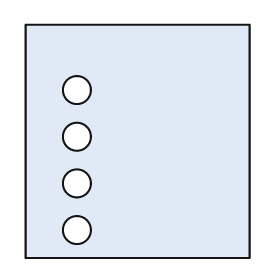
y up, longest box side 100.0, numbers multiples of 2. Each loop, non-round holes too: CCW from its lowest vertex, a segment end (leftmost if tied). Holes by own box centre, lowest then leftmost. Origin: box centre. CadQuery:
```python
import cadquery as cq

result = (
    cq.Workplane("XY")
    .moveTo(-48.0, -50.0)
    .lineTo(48.0, -50.0)
    .lineTo(48.0, 50.0)
    .lineTo(-48.0, 50.0)
    .close()
    .moveTo(-26.0, -38.0)
    .circle(6.0)
    .moveTo(-26.0, -18.0)
    .circle(6.0)
    .moveTo(-26.0, 2.0)
    .circle(6.0)
    .moveTo(-26.0, 22.0)
    .circle(6.0)
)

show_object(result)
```